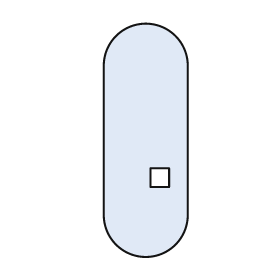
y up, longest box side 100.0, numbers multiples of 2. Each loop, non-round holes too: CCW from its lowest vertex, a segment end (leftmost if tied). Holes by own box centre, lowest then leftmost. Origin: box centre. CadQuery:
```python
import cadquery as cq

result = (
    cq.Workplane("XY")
    .moveTo(-18.0, -32.0)
    .threePointArc((0.0, -50.0), (18.0, -32.0))
    .lineTo(18.0, 32.0)
    .threePointArc((0.0, 50.0), (-18.0, 32.0))
    .close()
    .moveTo(2.0, -20.0)
    .lineTo(10.0, -20.0)
    .lineTo(10.0, -12.0)
    .lineTo(2.0, -12.0)
    .close()
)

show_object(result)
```